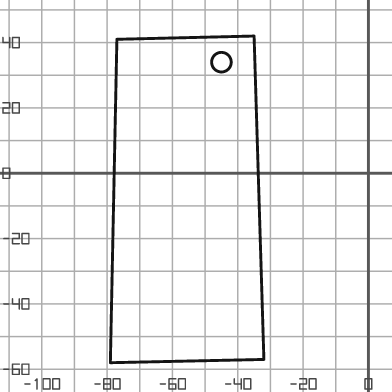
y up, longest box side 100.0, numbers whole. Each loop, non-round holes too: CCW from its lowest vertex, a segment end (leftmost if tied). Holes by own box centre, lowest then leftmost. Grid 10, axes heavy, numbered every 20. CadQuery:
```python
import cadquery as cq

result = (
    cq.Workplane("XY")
    .moveTo(-79.0, -58.0)
    .lineTo(-32.0, -57.0)
    .lineTo(-35.0, 42.0)
    .lineTo(-77.0, 41.0)
    .close()
    .moveTo(-45.0, 34.0)
    .circle(3.0)
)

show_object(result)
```